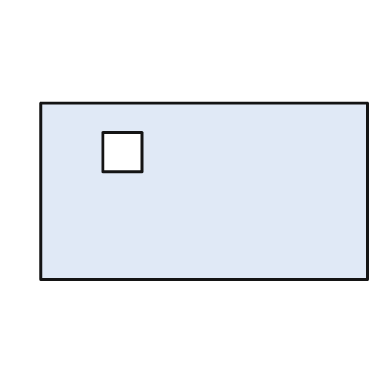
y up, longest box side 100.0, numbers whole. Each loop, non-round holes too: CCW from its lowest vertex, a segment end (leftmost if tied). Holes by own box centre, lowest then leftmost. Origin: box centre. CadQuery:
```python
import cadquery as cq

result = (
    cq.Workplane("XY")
    .moveTo(-50.0, -27.0)
    .lineTo(50.0, -27.0)
    .lineTo(50.0, 27.0)
    .lineTo(-50.0, 27.0)
    .close()
    .moveTo(-31.0, 6.0)
    .lineTo(-19.0, 6.0)
    .lineTo(-19.0, 18.0)
    .lineTo(-31.0, 18.0)
    .close()
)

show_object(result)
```